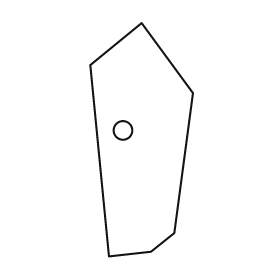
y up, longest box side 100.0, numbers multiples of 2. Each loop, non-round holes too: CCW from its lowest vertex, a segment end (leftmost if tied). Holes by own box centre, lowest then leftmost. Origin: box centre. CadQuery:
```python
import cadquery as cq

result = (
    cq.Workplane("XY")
    .moveTo(-14.0, -50.0)
    .lineTo(4.0, -48.0)
    .lineTo(14.0, -40.0)
    .lineTo(22.0, 20.0)
    .lineTo(0.0, 50.0)
    .lineTo(-22.0, 32.0)
    .close()
    .moveTo(-8.0, 4.0)
    .circle(4.0)
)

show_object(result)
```